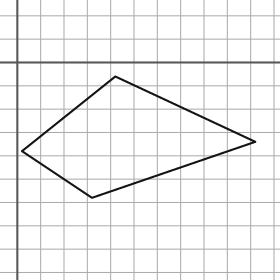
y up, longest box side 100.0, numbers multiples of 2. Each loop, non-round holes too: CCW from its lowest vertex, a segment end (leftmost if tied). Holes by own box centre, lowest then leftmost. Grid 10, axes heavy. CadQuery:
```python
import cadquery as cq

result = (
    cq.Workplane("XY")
    .moveTo(32.0, -58.0)
    .lineTo(102.0, -34.0)
    .lineTo(42.0, -6.0)
    .lineTo(2.0, -38.0)
    .close()
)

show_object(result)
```